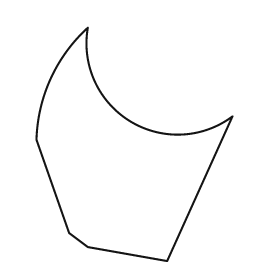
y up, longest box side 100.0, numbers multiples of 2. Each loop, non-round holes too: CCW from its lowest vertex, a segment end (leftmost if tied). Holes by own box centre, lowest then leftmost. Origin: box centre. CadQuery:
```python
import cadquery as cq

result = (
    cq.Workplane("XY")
    .moveTo(14.0, -50.0)
    .lineTo(42.0, 12.0)
    .threePointArc((-2.0, 10.0), (-20.0, 50.0))
    .threePointArc((-36.0, 28.0), (-42.0, 2.0))
    .lineTo(-28.0, -38.0)
    .lineTo(-20.0, -44.0)
    .close()
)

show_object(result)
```